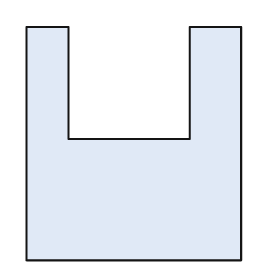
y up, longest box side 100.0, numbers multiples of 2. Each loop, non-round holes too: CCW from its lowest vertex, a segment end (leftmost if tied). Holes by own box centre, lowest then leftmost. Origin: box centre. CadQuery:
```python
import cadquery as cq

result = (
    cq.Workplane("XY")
    .moveTo(-46.0, -50.0)
    .lineTo(46.0, -50.0)
    .lineTo(46.0, 50.0)
    .lineTo(24.0, 50.0)
    .lineTo(24.0, 2.0)
    .lineTo(-28.0, 2.0)
    .lineTo(-28.0, 50.0)
    .lineTo(-46.0, 50.0)
    .close()
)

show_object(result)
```